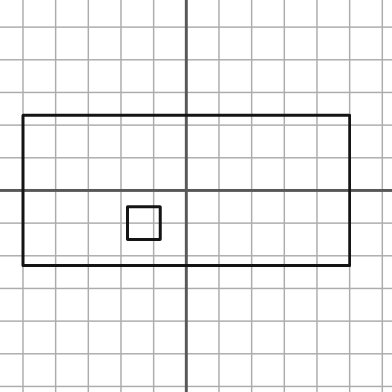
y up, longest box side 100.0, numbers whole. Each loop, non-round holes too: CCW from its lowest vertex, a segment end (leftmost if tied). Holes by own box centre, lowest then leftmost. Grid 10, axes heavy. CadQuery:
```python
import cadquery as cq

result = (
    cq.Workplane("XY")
    .moveTo(-50.0, -23.0)
    .lineTo(50.0, -23.0)
    .lineTo(50.0, 23.0)
    .lineTo(-50.0, 23.0)
    .close()
    .moveTo(-18.0, -15.0)
    .lineTo(-8.0, -15.0)
    .lineTo(-8.0, -5.0)
    .lineTo(-18.0, -5.0)
    .close()
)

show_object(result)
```